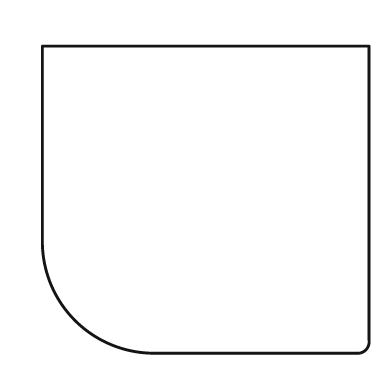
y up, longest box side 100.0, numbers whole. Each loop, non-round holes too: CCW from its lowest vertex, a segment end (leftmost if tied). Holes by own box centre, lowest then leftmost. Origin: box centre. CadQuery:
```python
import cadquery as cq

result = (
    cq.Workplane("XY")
    .moveTo(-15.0, -47.0)
    .lineTo(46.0, -47.0)
    .threePointArc((49.0, -46.0), (50.0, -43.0))
    .lineTo(50.0, 47.0)
    .lineTo(-50.0, 47.0)
    .lineTo(-50.0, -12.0)
    .threePointArc((-40.0, -37.0), (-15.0, -47.0))
    .close()
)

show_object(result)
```